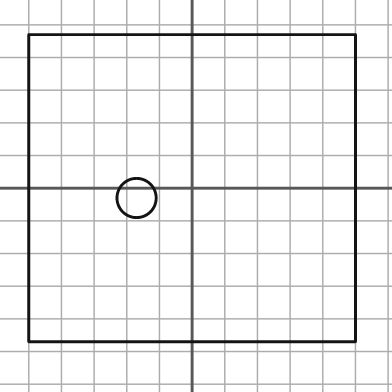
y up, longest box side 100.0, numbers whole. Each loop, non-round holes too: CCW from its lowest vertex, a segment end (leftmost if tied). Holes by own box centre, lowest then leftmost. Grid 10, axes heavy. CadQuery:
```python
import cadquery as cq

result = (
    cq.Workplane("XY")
    .moveTo(-50.0, -47.0)
    .lineTo(50.0, -47.0)
    .lineTo(50.0, 47.0)
    .lineTo(-50.0, 47.0)
    .close()
    .moveTo(-17.0, -3.0)
    .circle(6.0)
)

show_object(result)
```